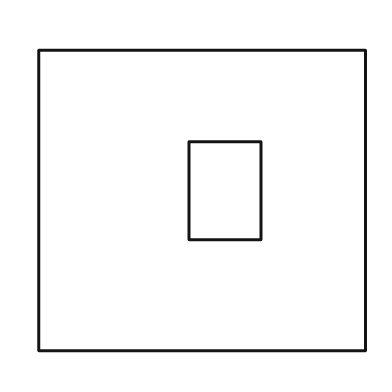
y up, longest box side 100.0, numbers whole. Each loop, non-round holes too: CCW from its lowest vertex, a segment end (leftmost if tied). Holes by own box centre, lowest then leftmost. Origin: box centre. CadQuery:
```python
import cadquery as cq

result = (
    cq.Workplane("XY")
    .moveTo(-50.0, -46.0)
    .lineTo(50.0, -46.0)
    .lineTo(50.0, 46.0)
    .lineTo(-50.0, 46.0)
    .close()
    .moveTo(-4.0, -12.0)
    .lineTo(18.0, -12.0)
    .lineTo(18.0, 18.0)
    .lineTo(-4.0, 18.0)
    .close()
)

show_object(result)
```